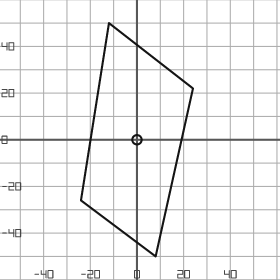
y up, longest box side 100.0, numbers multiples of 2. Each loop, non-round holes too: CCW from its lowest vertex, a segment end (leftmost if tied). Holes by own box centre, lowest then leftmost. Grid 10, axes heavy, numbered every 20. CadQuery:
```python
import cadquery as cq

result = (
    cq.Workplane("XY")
    .moveTo(8.0, -50.0)
    .lineTo(24.0, 22.0)
    .lineTo(-12.0, 50.0)
    .lineTo(-24.0, -26.0)
    .close()
    .moveTo(0.0, 0.0)
    .circle(2.0)
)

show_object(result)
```